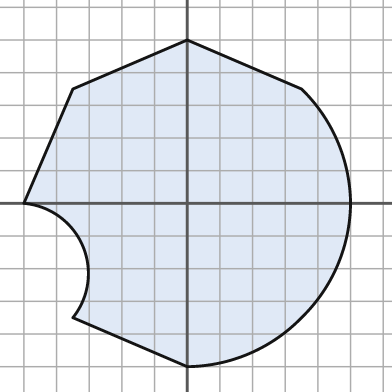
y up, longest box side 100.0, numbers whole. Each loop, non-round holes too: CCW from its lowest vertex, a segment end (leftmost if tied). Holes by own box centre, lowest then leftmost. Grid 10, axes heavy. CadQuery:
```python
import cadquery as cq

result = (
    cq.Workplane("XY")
    .moveTo(0.0, -50.0)
    .threePointArc((19.0, -46.0), (35.0, -35.0))
    .threePointArc((46.0, -19.0), (50.0, 0.0))
    .threePointArc((46.0, 19.0), (35.0, 35.0))
    .lineTo(0.0, 50.0)
    .lineTo(-35.0, 35.0)
    .lineTo(-50.0, 0.0)
    .threePointArc((-32.0, -13.0), (-35.0, -35.0))
    .close()
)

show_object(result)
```